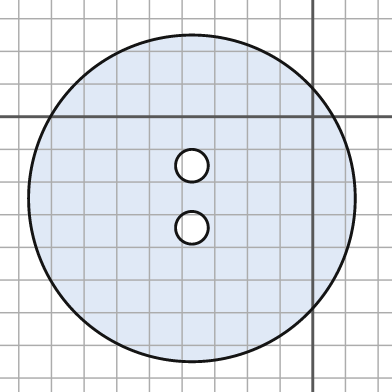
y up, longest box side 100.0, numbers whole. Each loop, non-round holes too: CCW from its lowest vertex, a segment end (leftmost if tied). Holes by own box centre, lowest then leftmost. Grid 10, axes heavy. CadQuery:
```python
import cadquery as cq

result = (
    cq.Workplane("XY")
    .moveTo(-37.0, -25.0)
    .circle(50.0)
    .moveTo(-37.0, -34.0)
    .circle(5.0)
    .moveTo(-37.0, -15.0)
    .circle(5.0)
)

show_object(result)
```